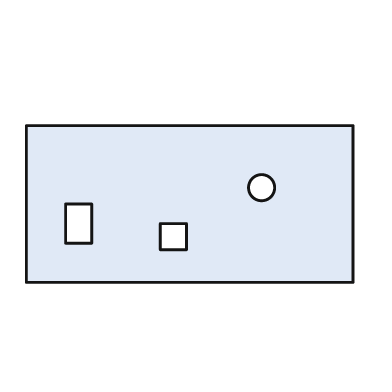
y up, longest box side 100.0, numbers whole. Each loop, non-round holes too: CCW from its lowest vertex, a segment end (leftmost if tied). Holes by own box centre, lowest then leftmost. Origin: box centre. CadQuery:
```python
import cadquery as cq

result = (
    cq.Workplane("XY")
    .moveTo(-50.0, -24.0)
    .lineTo(50.0, -24.0)
    .lineTo(50.0, 24.0)
    .lineTo(-50.0, 24.0)
    .close()
    .moveTo(-9.0, -14.0)
    .lineTo(-1.0, -14.0)
    .lineTo(-1.0, -6.0)
    .lineTo(-9.0, -6.0)
    .close()
    .moveTo(-38.0, -12.0)
    .lineTo(-30.0, -12.0)
    .lineTo(-30.0, 0.0)
    .lineTo(-38.0, 0.0)
    .close()
    .moveTo(22.0, 5.0)
    .circle(4.0)
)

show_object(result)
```